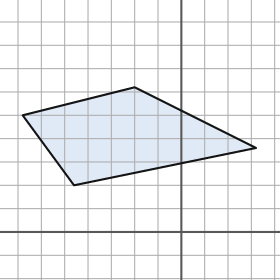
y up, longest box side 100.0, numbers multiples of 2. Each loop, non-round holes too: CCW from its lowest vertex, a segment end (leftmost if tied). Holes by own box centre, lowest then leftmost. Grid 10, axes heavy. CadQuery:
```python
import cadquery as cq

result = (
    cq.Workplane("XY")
    .moveTo(-46.0, 20.0)
    .lineTo(32.0, 36.0)
    .lineTo(-20.0, 62.0)
    .lineTo(-68.0, 50.0)
    .close()
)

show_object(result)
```